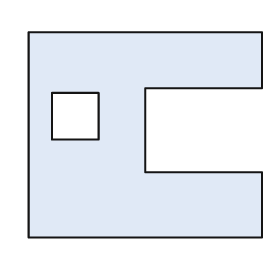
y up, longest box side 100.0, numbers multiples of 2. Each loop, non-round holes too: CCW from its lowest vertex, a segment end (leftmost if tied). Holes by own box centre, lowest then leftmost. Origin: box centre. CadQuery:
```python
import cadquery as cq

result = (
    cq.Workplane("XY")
    .moveTo(-50.0, -44.0)
    .lineTo(50.0, -44.0)
    .lineTo(50.0, -16.0)
    .lineTo(0.0, -16.0)
    .lineTo(0.0, 20.0)
    .lineTo(50.0, 20.0)
    .lineTo(50.0, 44.0)
    .lineTo(-50.0, 44.0)
    .close()
    .moveTo(-40.0, -2.0)
    .lineTo(-20.0, -2.0)
    .lineTo(-20.0, 18.0)
    .lineTo(-40.0, 18.0)
    .close()
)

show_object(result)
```